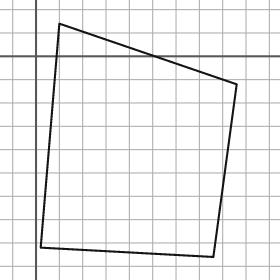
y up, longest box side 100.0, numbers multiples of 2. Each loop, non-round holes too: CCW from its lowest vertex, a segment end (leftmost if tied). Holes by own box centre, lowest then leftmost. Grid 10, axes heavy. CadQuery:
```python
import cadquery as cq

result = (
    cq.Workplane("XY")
    .moveTo(76.0, -86.0)
    .lineTo(86.0, -12.0)
    .lineTo(10.0, 14.0)
    .lineTo(2.0, -82.0)
    .close()
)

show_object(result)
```